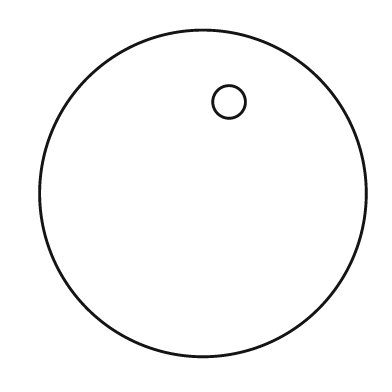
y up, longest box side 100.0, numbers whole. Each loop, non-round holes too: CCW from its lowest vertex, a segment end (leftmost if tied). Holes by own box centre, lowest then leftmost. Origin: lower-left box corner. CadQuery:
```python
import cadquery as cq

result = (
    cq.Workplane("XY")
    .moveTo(50.0, 50.0)
    .circle(50.0)
    .moveTo(58.0, 78.0)
    .circle(5.0)
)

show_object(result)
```